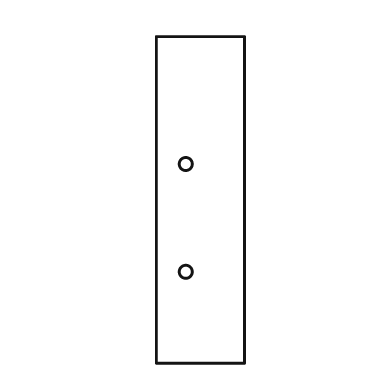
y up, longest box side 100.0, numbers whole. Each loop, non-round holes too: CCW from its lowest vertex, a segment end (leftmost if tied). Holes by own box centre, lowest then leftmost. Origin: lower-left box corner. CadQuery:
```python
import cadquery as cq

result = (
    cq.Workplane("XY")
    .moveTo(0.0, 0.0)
    .lineTo(27.0, 0.0)
    .lineTo(27.0, 100.0)
    .lineTo(0.0, 100.0)
    .close()
    .moveTo(9.0, 28.0)
    .circle(2.0)
    .moveTo(9.0, 61.0)
    .circle(2.0)
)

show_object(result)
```